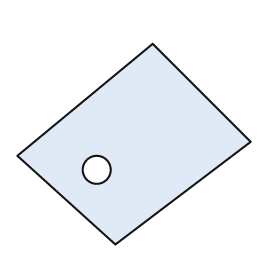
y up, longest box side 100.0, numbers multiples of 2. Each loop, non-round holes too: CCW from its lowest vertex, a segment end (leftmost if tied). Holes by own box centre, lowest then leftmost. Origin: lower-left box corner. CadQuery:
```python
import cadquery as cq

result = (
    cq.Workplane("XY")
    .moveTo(42.0, 0.0)
    .lineTo(100.0, 44.0)
    .lineTo(58.0, 86.0)
    .lineTo(0.0, 38.0)
    .close()
    .moveTo(34.0, 32.0)
    .circle(6.0)
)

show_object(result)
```